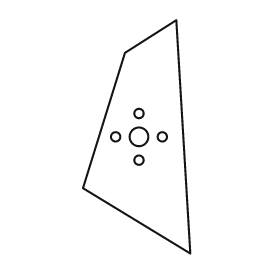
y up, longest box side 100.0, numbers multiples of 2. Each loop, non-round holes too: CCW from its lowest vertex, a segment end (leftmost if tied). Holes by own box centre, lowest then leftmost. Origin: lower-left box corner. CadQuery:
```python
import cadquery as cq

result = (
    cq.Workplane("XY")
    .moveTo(46.0, 0.0)
    .lineTo(40.0, 100.0)
    .lineTo(18.0, 86.0)
    .lineTo(0.0, 28.0)
    .close()
    .moveTo(24.0, 40.0)
    .circle(2.0)
    .moveTo(14.0, 50.0)
    .circle(2.0)
    .moveTo(24.0, 50.0)
    .circle(4.0)
    .moveTo(34.0, 50.0)
    .circle(2.0)
    .moveTo(24.0, 60.0)
    .circle(2.0)
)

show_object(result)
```